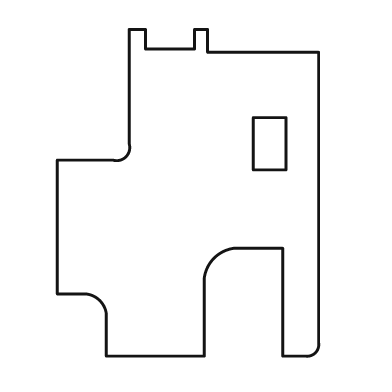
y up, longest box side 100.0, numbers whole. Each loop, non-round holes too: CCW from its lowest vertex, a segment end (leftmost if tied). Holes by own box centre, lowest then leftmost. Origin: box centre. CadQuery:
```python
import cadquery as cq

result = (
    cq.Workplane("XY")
    .moveTo(-25.0, -50.0)
    .lineTo(5.0, -50.0)
    .lineTo(5.0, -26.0)
    .threePointArc((8.0, -20.0), (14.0, -17.0))
    .lineTo(29.0, -17.0)
    .lineTo(29.0, -50.0)
    .lineTo(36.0, -50.0)
    .threePointArc((39.0, -49.0), (40.0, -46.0))
    .lineTo(40.0, 43.0)
    .lineTo(6.0, 43.0)
    .lineTo(6.0, 50.0)
    .lineTo(2.0, 50.0)
    .lineTo(2.0, 44.0)
    .lineTo(-13.0, 44.0)
    .lineTo(-13.0, 50.0)
    .lineTo(-18.0, 50.0)
    .lineTo(-18.0, 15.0)
    .threePointArc((-19.0, 11.0), (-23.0, 10.0))
    .lineTo(-40.0, 10.0)
    .lineTo(-40.0, -31.0)
    .lineTo(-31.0, -31.0)
    .threePointArc((-27.0, -33.0), (-25.0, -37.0))
    .close()
    .moveTo(20.0, 7.0)
    .lineTo(30.0, 7.0)
    .lineTo(30.0, 23.0)
    .lineTo(20.0, 23.0)
    .close()
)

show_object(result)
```